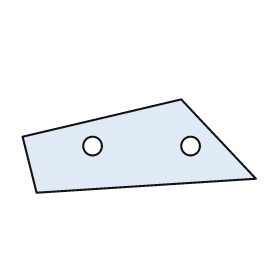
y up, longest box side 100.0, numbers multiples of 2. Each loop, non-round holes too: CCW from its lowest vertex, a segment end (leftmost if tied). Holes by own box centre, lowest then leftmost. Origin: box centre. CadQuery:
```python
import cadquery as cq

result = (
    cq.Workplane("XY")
    .moveTo(-44.0, -20.0)
    .lineTo(50.0, -14.0)
    .lineTo(18.0, 20.0)
    .lineTo(-50.0, 4.0)
    .close()
    .moveTo(-20.0, 0.0)
    .circle(4.0)
    .moveTo(22.0, 0.0)
    .circle(4.0)
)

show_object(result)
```